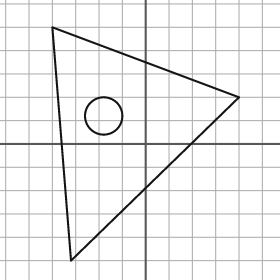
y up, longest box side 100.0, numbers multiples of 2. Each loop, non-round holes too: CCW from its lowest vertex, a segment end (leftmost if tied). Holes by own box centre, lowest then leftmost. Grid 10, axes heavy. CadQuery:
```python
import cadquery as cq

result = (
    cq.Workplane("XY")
    .moveTo(-32.0, -50.0)
    .lineTo(40.0, 20.0)
    .lineTo(-40.0, 50.0)
    .close()
    .moveTo(-18.0, 12.0)
    .circle(8.0)
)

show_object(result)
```